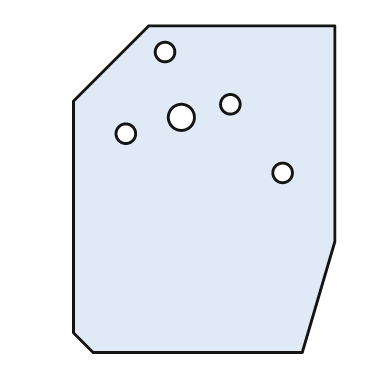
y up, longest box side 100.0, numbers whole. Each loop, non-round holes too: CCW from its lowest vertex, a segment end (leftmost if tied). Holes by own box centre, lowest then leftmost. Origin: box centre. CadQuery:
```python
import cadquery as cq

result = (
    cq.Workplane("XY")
    .moveTo(-34.0, -50.0)
    .lineTo(30.0, -50.0)
    .lineTo(40.0, -16.0)
    .lineTo(40.0, 50.0)
    .lineTo(-17.0, 50.0)
    .lineTo(-40.0, 27.0)
    .lineTo(-40.0, -44.0)
    .close()
    .moveTo(24.0, 5.0)
    .circle(3.0)
    .moveTo(-24.0, 17.0)
    .circle(3.0)
    .moveTo(-7.0, 22.0)
    .circle(4.0)
    .moveTo(8.0, 26.0)
    .circle(3.0)
    .moveTo(-12.0, 42.0)
    .circle(3.0)
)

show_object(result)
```